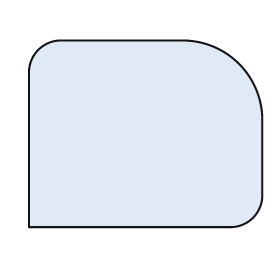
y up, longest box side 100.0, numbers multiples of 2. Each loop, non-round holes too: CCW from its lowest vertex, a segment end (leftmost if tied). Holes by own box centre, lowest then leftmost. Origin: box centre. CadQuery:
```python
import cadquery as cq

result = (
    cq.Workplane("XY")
    .moveTo(-50.0, -40.0)
    .lineTo(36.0, -40.0)
    .threePointArc((46.0, -36.0), (50.0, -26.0))
    .lineTo(50.0, 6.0)
    .threePointArc((40.0, 30.0), (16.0, 40.0))
    .lineTo(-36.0, 40.0)
    .threePointArc((-46.0, 36.0), (-50.0, 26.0))
    .close()
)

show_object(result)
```